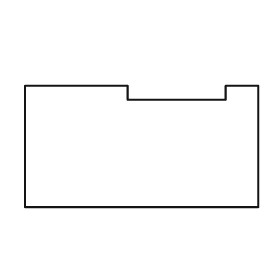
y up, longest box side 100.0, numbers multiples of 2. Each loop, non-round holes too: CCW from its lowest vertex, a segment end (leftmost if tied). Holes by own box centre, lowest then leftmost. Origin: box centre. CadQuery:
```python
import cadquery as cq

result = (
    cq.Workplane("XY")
    .moveTo(-50.0, -26.0)
    .lineTo(50.0, -26.0)
    .lineTo(50.0, 26.0)
    .lineTo(36.0, 26.0)
    .lineTo(36.0, 20.0)
    .lineTo(-6.0, 20.0)
    .lineTo(-6.0, 26.0)
    .lineTo(-50.0, 26.0)
    .close()
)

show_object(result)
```